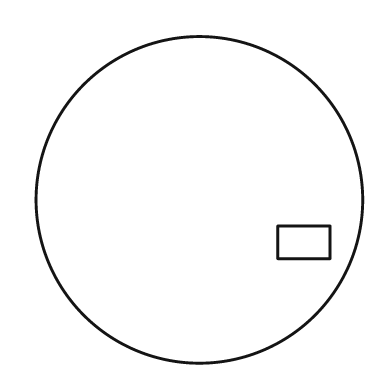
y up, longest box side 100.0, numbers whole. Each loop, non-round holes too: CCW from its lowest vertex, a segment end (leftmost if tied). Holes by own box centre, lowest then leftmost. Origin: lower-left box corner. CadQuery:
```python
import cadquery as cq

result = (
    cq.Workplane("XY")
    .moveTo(50.0, 50.0)
    .circle(50.0)
    .moveTo(74.0, 32.0)
    .lineTo(90.0, 32.0)
    .lineTo(90.0, 42.0)
    .lineTo(74.0, 42.0)
    .close()
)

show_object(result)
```